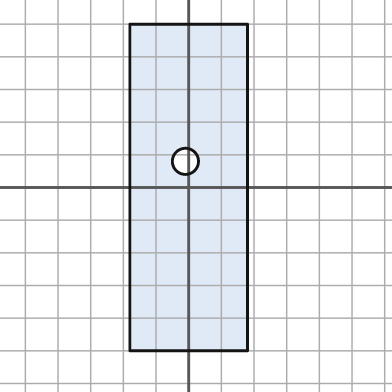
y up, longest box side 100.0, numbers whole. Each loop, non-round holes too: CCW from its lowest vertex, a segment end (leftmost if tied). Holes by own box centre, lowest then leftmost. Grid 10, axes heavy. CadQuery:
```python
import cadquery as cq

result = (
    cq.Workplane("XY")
    .moveTo(-18.0, -50.0)
    .lineTo(18.0, -50.0)
    .lineTo(18.0, 50.0)
    .lineTo(-18.0, 50.0)
    .close()
    .moveTo(-1.0, 8.0)
    .circle(4.0)
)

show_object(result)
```